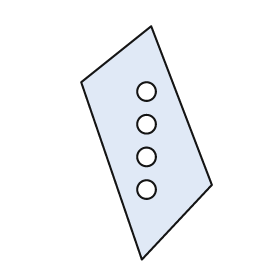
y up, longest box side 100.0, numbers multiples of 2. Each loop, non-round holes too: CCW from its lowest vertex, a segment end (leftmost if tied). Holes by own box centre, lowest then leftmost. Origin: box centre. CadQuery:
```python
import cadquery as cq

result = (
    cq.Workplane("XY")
    .moveTo(-2.0, -50.0)
    .lineTo(28.0, -18.0)
    .lineTo(2.0, 50.0)
    .lineTo(-28.0, 26.0)
    .close()
    .moveTo(0.0, -20.0)
    .circle(4.0)
    .moveTo(0.0, -6.0)
    .circle(4.0)
    .moveTo(0.0, 8.0)
    .circle(4.0)
    .moveTo(0.0, 22.0)
    .circle(4.0)
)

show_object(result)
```